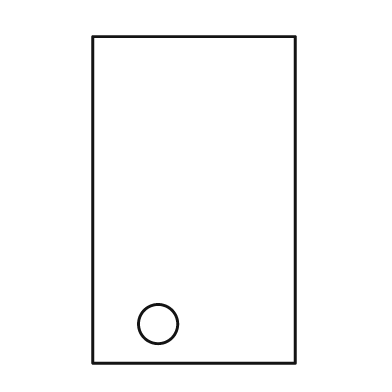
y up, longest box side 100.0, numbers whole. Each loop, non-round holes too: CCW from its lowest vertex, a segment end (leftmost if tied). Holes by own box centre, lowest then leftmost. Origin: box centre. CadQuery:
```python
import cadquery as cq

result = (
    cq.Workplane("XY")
    .moveTo(-31.0, -50.0)
    .lineTo(31.0, -50.0)
    .lineTo(31.0, 50.0)
    .lineTo(-31.0, 50.0)
    .close()
    .moveTo(-11.0, -38.0)
    .circle(6.0)
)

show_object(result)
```